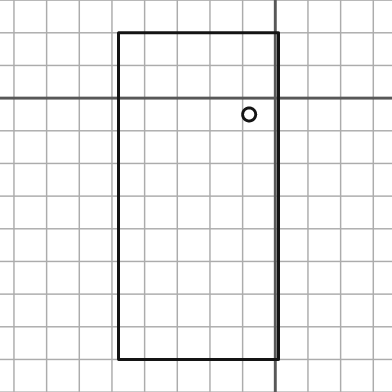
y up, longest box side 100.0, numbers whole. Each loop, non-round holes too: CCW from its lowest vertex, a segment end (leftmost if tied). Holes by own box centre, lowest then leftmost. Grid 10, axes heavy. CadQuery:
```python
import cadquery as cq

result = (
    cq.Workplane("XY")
    .moveTo(-48.0, -80.0)
    .lineTo(1.0, -80.0)
    .lineTo(1.0, 20.0)
    .lineTo(-48.0, 20.0)
    .close()
    .moveTo(-8.0, -5.0)
    .circle(2.0)
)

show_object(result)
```